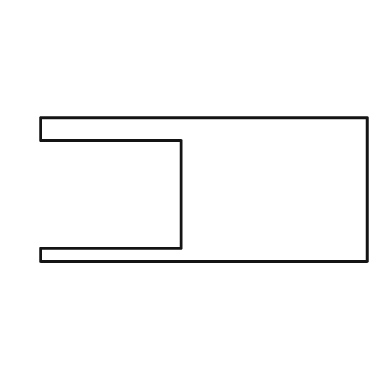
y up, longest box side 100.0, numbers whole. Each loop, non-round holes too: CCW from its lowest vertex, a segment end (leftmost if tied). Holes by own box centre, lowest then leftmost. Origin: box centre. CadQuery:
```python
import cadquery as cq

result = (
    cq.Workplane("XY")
    .moveTo(-50.0, -22.0)
    .lineTo(50.0, -22.0)
    .lineTo(50.0, 22.0)
    .lineTo(-50.0, 22.0)
    .lineTo(-50.0, 15.0)
    .lineTo(-7.0, 15.0)
    .lineTo(-7.0, -18.0)
    .lineTo(-50.0, -18.0)
    .close()
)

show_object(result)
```